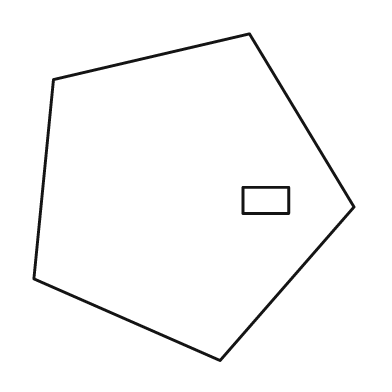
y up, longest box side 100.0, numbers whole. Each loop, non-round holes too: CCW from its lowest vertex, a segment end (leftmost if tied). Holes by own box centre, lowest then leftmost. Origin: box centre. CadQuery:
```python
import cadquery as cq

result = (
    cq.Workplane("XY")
    .moveTo(8.0, -50.0)
    .lineTo(49.0, -3.0)
    .lineTo(17.0, 50.0)
    .lineTo(-43.0, 36.0)
    .lineTo(-49.0, -25.0)
    .close()
    .moveTo(15.0, -5.0)
    .lineTo(29.0, -5.0)
    .lineTo(29.0, 3.0)
    .lineTo(15.0, 3.0)
    .close()
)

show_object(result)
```